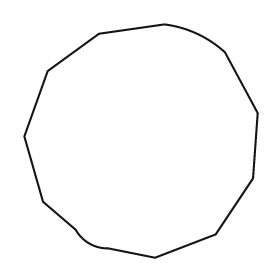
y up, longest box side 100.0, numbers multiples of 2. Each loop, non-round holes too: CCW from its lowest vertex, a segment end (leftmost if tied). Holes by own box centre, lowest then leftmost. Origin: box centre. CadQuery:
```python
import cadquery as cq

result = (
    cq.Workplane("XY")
    .moveTo(6.0, -50.0)
    .lineTo(32.0, -40.0)
    .lineTo(48.0, -16.0)
    .lineTo(50.0, 12.0)
    .lineTo(36.0, 38.0)
    .threePointArc((24.0, 46.0), (10.0, 50.0))
    .lineTo(-18.0, 46.0)
    .lineTo(-40.0, 30.0)
    .lineTo(-50.0, 2.0)
    .lineTo(-42.0, -26.0)
    .lineTo(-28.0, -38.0)
    .threePointArc((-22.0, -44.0), (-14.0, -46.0))
    .close()
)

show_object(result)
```